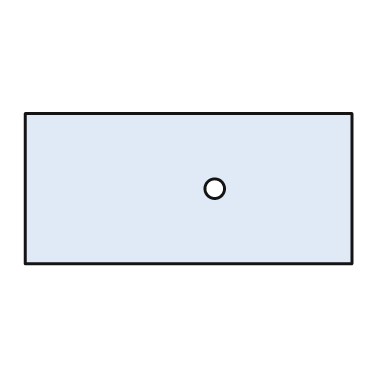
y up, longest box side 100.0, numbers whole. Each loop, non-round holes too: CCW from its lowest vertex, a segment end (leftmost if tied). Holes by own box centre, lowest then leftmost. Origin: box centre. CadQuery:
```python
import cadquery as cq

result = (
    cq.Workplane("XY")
    .moveTo(-50.0, -23.0)
    .lineTo(50.0, -23.0)
    .lineTo(50.0, 23.0)
    .lineTo(-50.0, 23.0)
    .close()
    .moveTo(8.0, 0.0)
    .circle(3.0)
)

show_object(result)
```